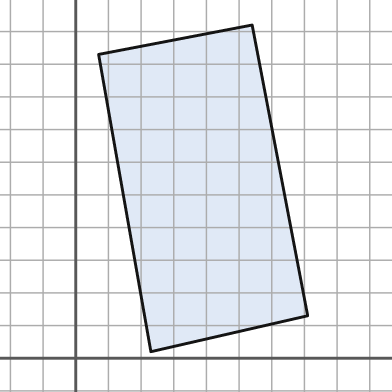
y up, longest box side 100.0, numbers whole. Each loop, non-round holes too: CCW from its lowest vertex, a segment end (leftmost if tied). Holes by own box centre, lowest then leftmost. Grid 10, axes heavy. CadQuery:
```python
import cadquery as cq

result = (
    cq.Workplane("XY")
    .moveTo(23.0, 2.0)
    .lineTo(71.0, 13.0)
    .lineTo(54.0, 102.0)
    .lineTo(7.0, 93.0)
    .close()
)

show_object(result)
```